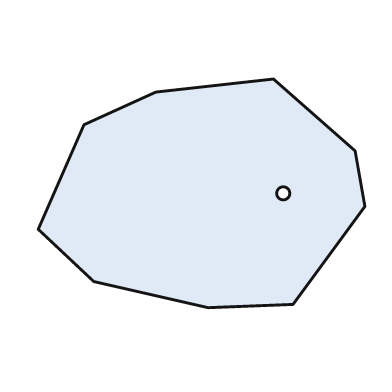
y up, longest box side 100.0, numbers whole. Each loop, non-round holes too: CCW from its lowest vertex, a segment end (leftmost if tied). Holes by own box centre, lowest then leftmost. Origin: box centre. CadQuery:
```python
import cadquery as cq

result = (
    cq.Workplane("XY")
    .moveTo(2.0, -35.0)
    .lineTo(28.0, -34.0)
    .lineTo(50.0, -4.0)
    .lineTo(47.0, 13.0)
    .lineTo(22.0, 35.0)
    .lineTo(-14.0, 31.0)
    .lineTo(-36.0, 21.0)
    .lineTo(-50.0, -11.0)
    .lineTo(-33.0, -27.0)
    .close()
    .moveTo(25.0, 0.0)
    .circle(2.0)
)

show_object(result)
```